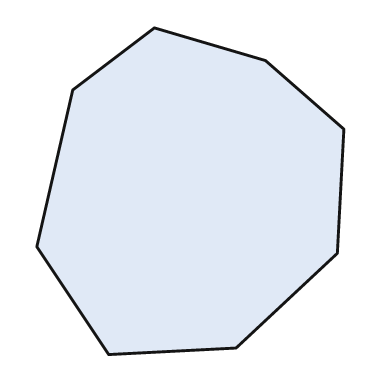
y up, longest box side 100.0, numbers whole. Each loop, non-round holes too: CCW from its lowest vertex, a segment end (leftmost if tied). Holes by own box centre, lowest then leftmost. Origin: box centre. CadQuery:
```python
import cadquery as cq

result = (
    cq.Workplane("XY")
    .moveTo(-25.0, -50.0)
    .lineTo(14.0, -48.0)
    .lineTo(45.0, -19.0)
    .lineTo(47.0, 19.0)
    .lineTo(23.0, 40.0)
    .lineTo(-11.0, 50.0)
    .lineTo(-36.0, 31.0)
    .lineTo(-47.0, -17.0)
    .close()
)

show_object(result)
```